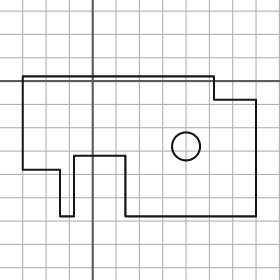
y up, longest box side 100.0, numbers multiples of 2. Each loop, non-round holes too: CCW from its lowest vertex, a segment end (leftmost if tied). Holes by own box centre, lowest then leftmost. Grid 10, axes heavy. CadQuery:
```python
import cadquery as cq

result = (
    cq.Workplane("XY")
    .moveTo(-14.0, -58.0)
    .lineTo(-8.0, -58.0)
    .lineTo(-8.0, -32.0)
    .lineTo(14.0, -32.0)
    .lineTo(14.0, -58.0)
    .lineTo(70.0, -58.0)
    .lineTo(70.0, -8.0)
    .lineTo(52.0, -8.0)
    .lineTo(52.0, 2.0)
    .lineTo(-30.0, 2.0)
    .lineTo(-30.0, -38.0)
    .lineTo(-14.0, -38.0)
    .close()
    .moveTo(40.0, -28.0)
    .circle(6.0)
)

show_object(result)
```